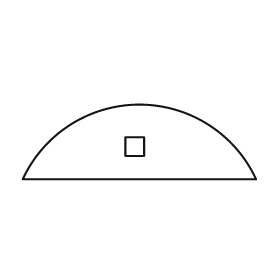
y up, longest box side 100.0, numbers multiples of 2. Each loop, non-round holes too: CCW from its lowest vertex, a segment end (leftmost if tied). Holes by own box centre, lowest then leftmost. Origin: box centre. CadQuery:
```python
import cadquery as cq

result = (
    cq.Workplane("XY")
    .moveTo(-50.0, -16.0)
    .lineTo(50.0, -16.0)
    .threePointArc((0.0, 16.0), (-50.0, -16.0))
    .close()
    .moveTo(-6.0, -6.0)
    .lineTo(2.0, -6.0)
    .lineTo(2.0, 2.0)
    .lineTo(-6.0, 2.0)
    .close()
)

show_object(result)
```